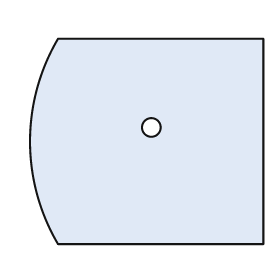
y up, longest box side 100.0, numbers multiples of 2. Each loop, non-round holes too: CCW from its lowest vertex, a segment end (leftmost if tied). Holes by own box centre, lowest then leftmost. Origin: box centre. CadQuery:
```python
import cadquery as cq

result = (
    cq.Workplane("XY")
    .moveTo(-38.0, -44.0)
    .lineTo(50.0, -44.0)
    .lineTo(50.0, 44.0)
    .lineTo(-38.0, 44.0)
    .threePointArc((-50.0, 0.0), (-38.0, -44.0))
    .close()
    .moveTo(2.0, 6.0)
    .circle(4.0)
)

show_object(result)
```